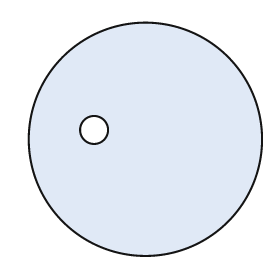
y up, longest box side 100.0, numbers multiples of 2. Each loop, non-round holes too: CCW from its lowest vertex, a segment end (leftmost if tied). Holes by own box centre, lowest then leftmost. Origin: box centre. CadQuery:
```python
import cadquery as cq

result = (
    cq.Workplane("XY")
    .moveTo(0.0, 0.0)
    .circle(50.0)
    .moveTo(-22.0, 4.0)
    .circle(6.0)
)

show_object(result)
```